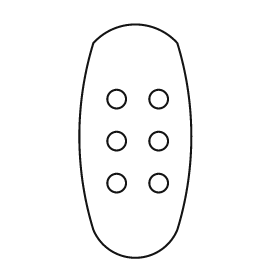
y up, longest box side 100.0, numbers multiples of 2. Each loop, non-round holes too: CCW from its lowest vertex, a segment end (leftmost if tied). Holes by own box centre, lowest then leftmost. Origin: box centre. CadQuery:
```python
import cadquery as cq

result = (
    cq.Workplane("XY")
    .moveTo(-18.0, -38.0)
    .threePointArc((0.0, -50.0), (18.0, -38.0))
    .threePointArc((24.0, 2.0), (18.0, 42.0))
    .threePointArc((0.0, 50.0), (-18.0, 42.0))
    .threePointArc((-24.0, 2.0), (-18.0, -38.0))
    .close()
    .moveTo(-8.0, -18.0)
    .circle(4.0)
    .moveTo(10.0, -18.0)
    .circle(4.0)
    .moveTo(-8.0, 0.0)
    .circle(4.0)
    .moveTo(10.0, 0.0)
    .circle(4.0)
    .moveTo(-8.0, 18.0)
    .circle(4.0)
    .moveTo(10.0, 18.0)
    .circle(4.0)
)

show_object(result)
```